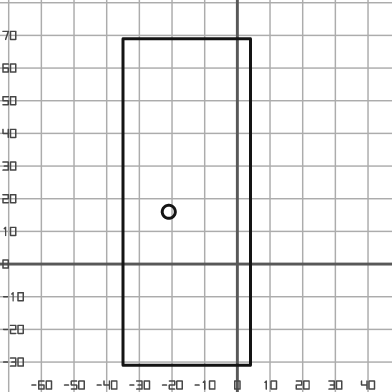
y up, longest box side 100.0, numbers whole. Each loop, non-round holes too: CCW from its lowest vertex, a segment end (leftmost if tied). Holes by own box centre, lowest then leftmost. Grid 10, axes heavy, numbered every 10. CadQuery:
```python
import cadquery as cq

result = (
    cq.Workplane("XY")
    .moveTo(-35.0, -31.0)
    .lineTo(4.0, -31.0)
    .lineTo(4.0, 69.0)
    .lineTo(-35.0, 69.0)
    .close()
    .moveTo(-21.0, 16.0)
    .circle(2.0)
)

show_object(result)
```